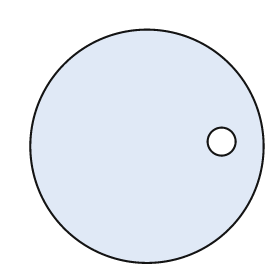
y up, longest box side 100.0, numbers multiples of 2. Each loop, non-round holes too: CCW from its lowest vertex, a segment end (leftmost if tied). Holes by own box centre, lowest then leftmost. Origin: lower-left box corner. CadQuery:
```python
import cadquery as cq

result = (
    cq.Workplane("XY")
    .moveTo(50.0, 50.0)
    .circle(50.0)
    .moveTo(82.0, 52.0)
    .circle(6.0)
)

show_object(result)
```